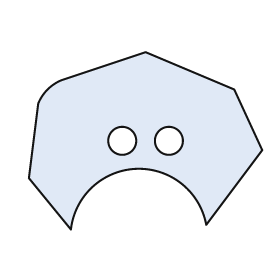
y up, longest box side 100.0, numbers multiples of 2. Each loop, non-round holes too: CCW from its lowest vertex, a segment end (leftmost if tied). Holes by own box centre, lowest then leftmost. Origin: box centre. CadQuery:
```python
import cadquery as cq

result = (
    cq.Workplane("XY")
    .moveTo(-32.0, -38.0)
    .threePointArc((-4.0, -12.0), (26.0, -36.0))
    .lineTo(50.0, -4.0)
    .lineTo(38.0, 22.0)
    .lineTo(0.0, 38.0)
    .lineTo(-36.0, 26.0)
    .threePointArc((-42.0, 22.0), (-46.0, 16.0))
    .lineTo(-50.0, -16.0)
    .close()
    .moveTo(-10.0, 0.0)
    .circle(6.0)
    .moveTo(10.0, 0.0)
    .circle(6.0)
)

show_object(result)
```